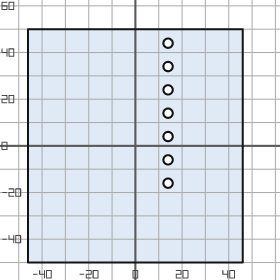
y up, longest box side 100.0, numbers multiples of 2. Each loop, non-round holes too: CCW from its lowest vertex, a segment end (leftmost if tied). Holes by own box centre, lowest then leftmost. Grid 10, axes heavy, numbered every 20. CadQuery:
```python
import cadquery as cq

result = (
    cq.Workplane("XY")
    .moveTo(-46.0, -50.0)
    .lineTo(46.0, -50.0)
    .lineTo(46.0, 50.0)
    .lineTo(-46.0, 50.0)
    .close()
    .moveTo(14.0, -16.0)
    .circle(2.0)
    .moveTo(14.0, -6.0)
    .circle(2.0)
    .moveTo(14.0, 4.0)
    .circle(2.0)
    .moveTo(14.0, 14.0)
    .circle(2.0)
    .moveTo(14.0, 24.0)
    .circle(2.0)
    .moveTo(14.0, 34.0)
    .circle(2.0)
    .moveTo(14.0, 44.0)
    .circle(2.0)
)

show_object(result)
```